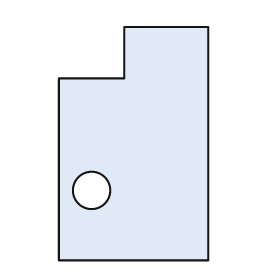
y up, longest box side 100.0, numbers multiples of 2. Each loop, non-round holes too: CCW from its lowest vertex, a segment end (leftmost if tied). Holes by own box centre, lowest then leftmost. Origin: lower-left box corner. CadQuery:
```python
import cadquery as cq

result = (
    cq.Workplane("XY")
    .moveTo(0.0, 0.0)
    .lineTo(64.0, 0.0)
    .lineTo(64.0, 100.0)
    .lineTo(28.0, 100.0)
    .lineTo(28.0, 78.0)
    .lineTo(0.0, 78.0)
    .close()
    .moveTo(14.0, 30.0)
    .circle(8.0)
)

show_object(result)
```